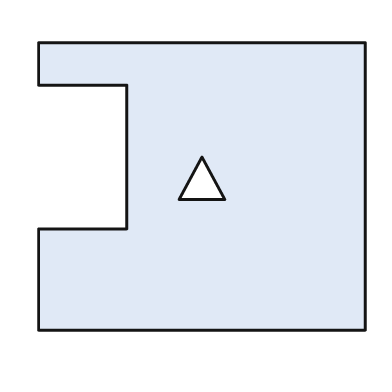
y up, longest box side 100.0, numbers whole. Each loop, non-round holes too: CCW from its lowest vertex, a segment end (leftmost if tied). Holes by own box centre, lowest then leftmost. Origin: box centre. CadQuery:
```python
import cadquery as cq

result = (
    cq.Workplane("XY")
    .moveTo(-50.0, -44.0)
    .lineTo(50.0, -44.0)
    .lineTo(50.0, 44.0)
    .lineTo(-50.0, 44.0)
    .lineTo(-50.0, 31.0)
    .lineTo(-23.0, 31.0)
    .lineTo(-23.0, -13.0)
    .lineTo(-50.0, -13.0)
    .close()
    .moveTo(-7.0, -4.0)
    .lineTo(7.0, -4.0)
    .lineTo(0.0, 9.0)
    .close()
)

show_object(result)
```